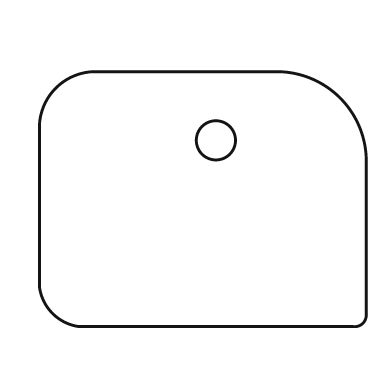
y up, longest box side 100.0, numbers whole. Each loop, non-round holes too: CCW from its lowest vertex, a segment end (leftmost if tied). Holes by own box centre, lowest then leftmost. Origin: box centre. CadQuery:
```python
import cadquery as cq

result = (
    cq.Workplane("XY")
    .moveTo(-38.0, -39.0)
    .lineTo(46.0, -39.0)
    .threePointArc((49.0, -38.0), (50.0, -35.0))
    .lineTo(50.0, 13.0)
    .threePointArc((42.0, 31.0), (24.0, 39.0))
    .lineTo(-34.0, 39.0)
    .threePointArc((-45.0, 34.0), (-50.0, 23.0))
    .lineTo(-50.0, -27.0)
    .threePointArc((-46.0, -35.0), (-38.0, -39.0))
    .close()
    .moveTo(4.0, 18.0)
    .circle(6.0)
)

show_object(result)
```